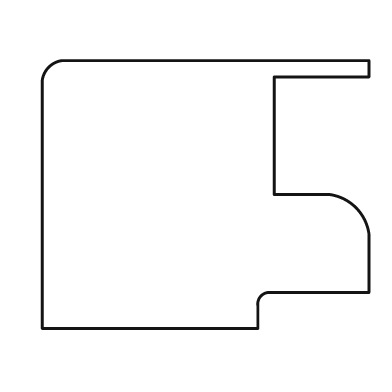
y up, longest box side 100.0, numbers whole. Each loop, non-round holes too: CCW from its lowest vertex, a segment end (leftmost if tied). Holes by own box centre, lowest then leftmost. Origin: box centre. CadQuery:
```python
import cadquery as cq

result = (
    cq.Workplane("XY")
    .moveTo(-50.0, -41.0)
    .lineTo(16.0, -41.0)
    .lineTo(16.0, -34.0)
    .threePointArc((17.0, -31.0), (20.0, -30.0))
    .lineTo(50.0, -30.0)
    .lineTo(50.0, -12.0)
    .threePointArc((46.0, -4.0), (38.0, 0.0))
    .lineTo(21.0, 0.0)
    .lineTo(21.0, 36.0)
    .lineTo(50.0, 36.0)
    .lineTo(50.0, 41.0)
    .lineTo(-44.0, 41.0)
    .threePointArc((-48.0, 39.0), (-50.0, 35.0))
    .close()
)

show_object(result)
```